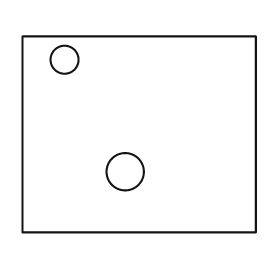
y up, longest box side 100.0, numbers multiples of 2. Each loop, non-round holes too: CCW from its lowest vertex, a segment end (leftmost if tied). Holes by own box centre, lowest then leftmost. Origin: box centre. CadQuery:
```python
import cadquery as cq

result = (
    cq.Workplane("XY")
    .moveTo(-50.0, -42.0)
    .lineTo(50.0, -42.0)
    .lineTo(50.0, 42.0)
    .lineTo(-50.0, 42.0)
    .close()
    .moveTo(-6.0, -16.0)
    .circle(8.0)
    .moveTo(-32.0, 32.0)
    .circle(6.0)
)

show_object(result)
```